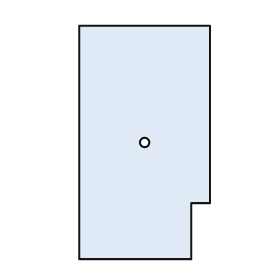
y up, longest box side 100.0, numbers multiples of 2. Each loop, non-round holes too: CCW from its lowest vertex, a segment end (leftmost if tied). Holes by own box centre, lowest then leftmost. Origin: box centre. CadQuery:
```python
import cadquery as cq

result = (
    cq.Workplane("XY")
    .moveTo(-28.0, -50.0)
    .lineTo(20.0, -50.0)
    .lineTo(20.0, -26.0)
    .lineTo(28.0, -26.0)
    .lineTo(28.0, 50.0)
    .lineTo(-28.0, 50.0)
    .close()
    .moveTo(0.0, 0.0)
    .circle(2.0)
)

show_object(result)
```